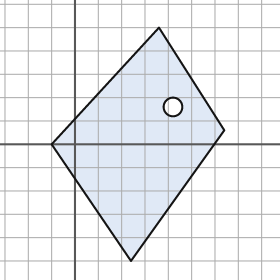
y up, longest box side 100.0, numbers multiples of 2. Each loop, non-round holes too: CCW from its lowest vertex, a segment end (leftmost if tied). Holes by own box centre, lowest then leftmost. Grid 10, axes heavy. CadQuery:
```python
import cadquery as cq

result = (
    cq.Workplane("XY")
    .moveTo(24.0, -50.0)
    .lineTo(64.0, 6.0)
    .lineTo(36.0, 50.0)
    .lineTo(-10.0, 0.0)
    .close()
    .moveTo(42.0, 16.0)
    .circle(4.0)
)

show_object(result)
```